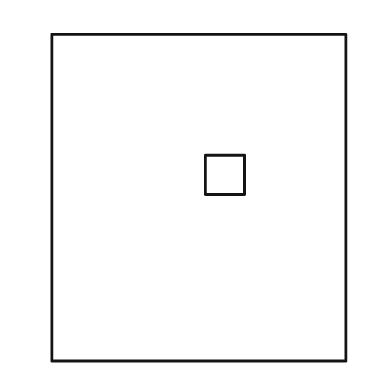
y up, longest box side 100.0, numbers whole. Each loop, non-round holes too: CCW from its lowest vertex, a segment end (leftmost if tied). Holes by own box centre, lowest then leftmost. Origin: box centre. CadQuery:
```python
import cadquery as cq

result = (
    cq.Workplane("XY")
    .moveTo(-45.0, -50.0)
    .lineTo(45.0, -50.0)
    .lineTo(45.0, 50.0)
    .lineTo(-45.0, 50.0)
    .close()
    .moveTo(2.0, 1.0)
    .lineTo(14.0, 1.0)
    .lineTo(14.0, 13.0)
    .lineTo(2.0, 13.0)
    .close()
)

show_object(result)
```